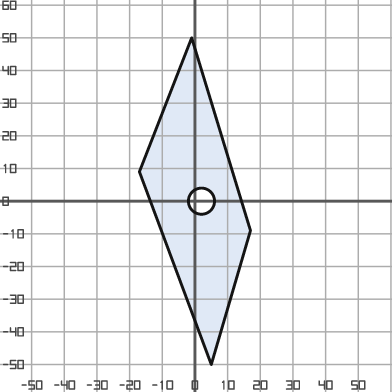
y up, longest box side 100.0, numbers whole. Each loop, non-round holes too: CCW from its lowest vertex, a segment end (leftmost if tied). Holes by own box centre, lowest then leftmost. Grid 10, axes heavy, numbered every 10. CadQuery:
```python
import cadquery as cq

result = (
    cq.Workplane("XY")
    .moveTo(5.0, -50.0)
    .lineTo(17.0, -9.0)
    .lineTo(-1.0, 50.0)
    .lineTo(-17.0, 9.0)
    .close()
    .moveTo(2.0, 0.0)
    .circle(4.0)
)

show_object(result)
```